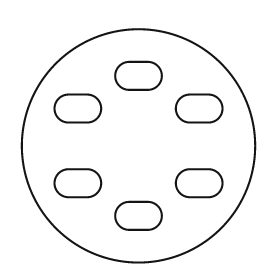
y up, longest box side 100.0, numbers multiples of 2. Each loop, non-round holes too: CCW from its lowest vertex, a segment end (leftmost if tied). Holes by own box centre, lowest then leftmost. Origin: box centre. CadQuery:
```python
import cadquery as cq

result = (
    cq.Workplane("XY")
    .moveTo(0.0, 0.0)
    .circle(50.0)
    .moveTo(-4.0, -36.0)
    .lineTo(4.0, -36.0)
    .threePointArc((10.0, -30.0), (4.0, -24.0))
    .lineTo(-4.0, -24.0)
    .threePointArc((-10.0, -30.0), (-4.0, -36.0))
    .close()
    .moveTo(-30.0, -22.0)
    .lineTo(-22.0, -22.0)
    .threePointArc((-16.0, -16.0), (-22.0, -10.0))
    .lineTo(-30.0, -10.0)
    .threePointArc((-36.0, -16.0), (-30.0, -22.0))
    .close()
    .moveTo(22.0, -22.0)
    .lineTo(30.0, -22.0)
    .threePointArc((36.0, -16.0), (30.0, -10.0))
    .lineTo(22.0, -10.0)
    .threePointArc((16.0, -16.0), (22.0, -22.0))
    .close()
    .moveTo(-30.0, 10.0)
    .lineTo(-22.0, 10.0)
    .threePointArc((-16.0, 16.0), (-22.0, 22.0))
    .lineTo(-30.0, 22.0)
    .threePointArc((-36.0, 16.0), (-30.0, 10.0))
    .close()
    .moveTo(22.0, 10.0)
    .lineTo(30.0, 10.0)
    .threePointArc((36.0, 16.0), (30.0, 22.0))
    .lineTo(22.0, 22.0)
    .threePointArc((16.0, 16.0), (22.0, 10.0))
    .close()
    .moveTo(-4.0, 24.0)
    .lineTo(4.0, 24.0)
    .threePointArc((10.0, 30.0), (4.0, 36.0))
    .lineTo(-4.0, 36.0)
    .threePointArc((-10.0, 30.0), (-4.0, 24.0))
    .close()
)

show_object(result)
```